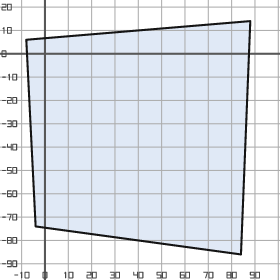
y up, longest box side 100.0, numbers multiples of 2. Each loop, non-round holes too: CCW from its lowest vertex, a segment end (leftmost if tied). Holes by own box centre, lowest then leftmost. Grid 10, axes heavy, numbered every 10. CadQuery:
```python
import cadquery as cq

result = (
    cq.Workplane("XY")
    .moveTo(84.0, -86.0)
    .lineTo(88.0, 14.0)
    .lineTo(-8.0, 6.0)
    .lineTo(-4.0, -74.0)
    .close()
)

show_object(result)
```